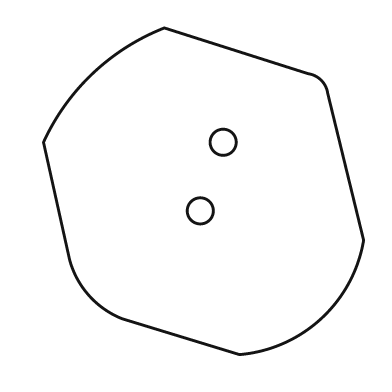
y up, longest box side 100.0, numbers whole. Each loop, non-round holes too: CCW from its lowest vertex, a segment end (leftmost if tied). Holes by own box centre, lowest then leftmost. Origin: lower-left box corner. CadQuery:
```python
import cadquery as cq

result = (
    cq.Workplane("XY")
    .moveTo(60.0, 0.0)
    .threePointArc((85.0, 11.0), (98.0, 35.0))
    .lineTo(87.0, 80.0)
    .threePointArc((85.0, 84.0), (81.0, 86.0))
    .lineTo(37.0, 100.0)
    .threePointArc((15.0, 86.0), (0.0, 65.0))
    .lineTo(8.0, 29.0)
    .threePointArc((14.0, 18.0), (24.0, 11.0))
    .close()
    .moveTo(48.0, 44.0)
    .circle(4.0)
    .moveTo(55.0, 65.0)
    .circle(4.0)
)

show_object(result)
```